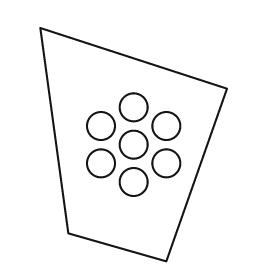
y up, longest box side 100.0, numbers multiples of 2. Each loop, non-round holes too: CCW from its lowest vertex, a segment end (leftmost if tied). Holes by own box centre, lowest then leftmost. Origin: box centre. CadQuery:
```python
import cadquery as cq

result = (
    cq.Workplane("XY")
    .moveTo(14.0, -50.0)
    .lineTo(40.0, 24.0)
    .lineTo(-40.0, 50.0)
    .lineTo(-28.0, -38.0)
    .close()
    .moveTo(0.0, -16.0)
    .circle(6.0)
    .moveTo(-14.0, -8.0)
    .circle(6.0)
    .moveTo(14.0, -8.0)
    .circle(6.0)
    .moveTo(0.0, 0.0)
    .circle(6.0)
    .moveTo(-14.0, 8.0)
    .circle(6.0)
    .moveTo(14.0, 8.0)
    .circle(6.0)
    .moveTo(0.0, 16.0)
    .circle(6.0)
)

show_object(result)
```